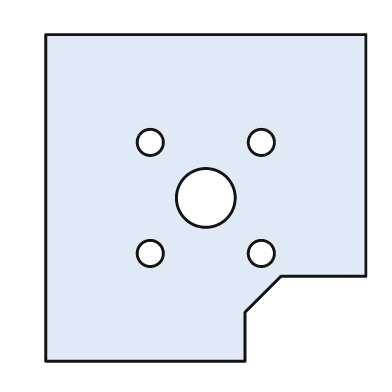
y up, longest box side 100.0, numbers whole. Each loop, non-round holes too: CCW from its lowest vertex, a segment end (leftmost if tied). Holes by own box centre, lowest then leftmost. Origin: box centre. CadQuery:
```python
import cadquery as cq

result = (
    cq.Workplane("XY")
    .moveTo(-49.0, -50.0)
    .lineTo(12.0, -50.0)
    .lineTo(12.0, -35.0)
    .lineTo(23.0, -24.0)
    .lineTo(49.0, -24.0)
    .lineTo(49.0, 50.0)
    .lineTo(-49.0, 50.0)
    .close()
    .moveTo(-17.0, -17.0)
    .circle(4.0)
    .moveTo(17.0, -17.0)
    .circle(4.0)
    .moveTo(0.0, 0.0)
    .circle(9.0)
    .moveTo(-17.0, 17.0)
    .circle(4.0)
    .moveTo(17.0, 17.0)
    .circle(4.0)
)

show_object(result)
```